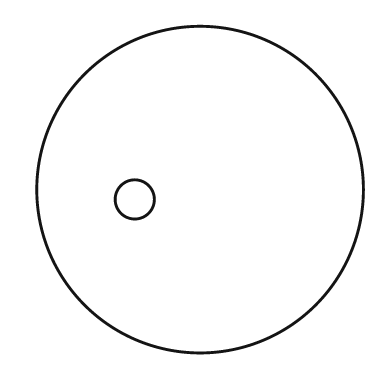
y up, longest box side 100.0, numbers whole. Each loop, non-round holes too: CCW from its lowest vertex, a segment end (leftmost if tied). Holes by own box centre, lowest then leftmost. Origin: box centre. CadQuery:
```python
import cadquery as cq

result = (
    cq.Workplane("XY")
    .moveTo(0.0, 0.0)
    .circle(50.0)
    .moveTo(-20.0, -3.0)
    .circle(6.0)
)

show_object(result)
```